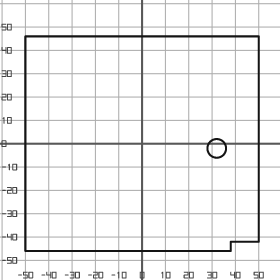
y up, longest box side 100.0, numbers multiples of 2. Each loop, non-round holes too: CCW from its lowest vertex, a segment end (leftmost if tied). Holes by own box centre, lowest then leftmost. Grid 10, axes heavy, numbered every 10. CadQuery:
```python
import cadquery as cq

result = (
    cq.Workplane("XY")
    .moveTo(-50.0, -46.0)
    .lineTo(38.0, -46.0)
    .lineTo(38.0, -42.0)
    .lineTo(50.0, -42.0)
    .lineTo(50.0, 46.0)
    .lineTo(-50.0, 46.0)
    .close()
    .moveTo(32.0, -2.0)
    .circle(4.0)
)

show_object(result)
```